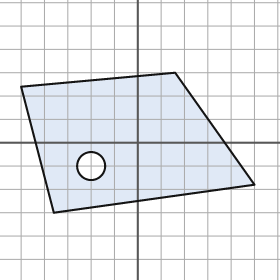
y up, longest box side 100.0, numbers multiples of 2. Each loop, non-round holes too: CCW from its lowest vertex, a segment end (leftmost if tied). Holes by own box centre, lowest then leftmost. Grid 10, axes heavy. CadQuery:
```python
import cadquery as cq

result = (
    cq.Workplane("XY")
    .moveTo(-36.0, -30.0)
    .lineTo(50.0, -18.0)
    .lineTo(16.0, 30.0)
    .lineTo(-50.0, 24.0)
    .close()
    .moveTo(-20.0, -10.0)
    .circle(6.0)
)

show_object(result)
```